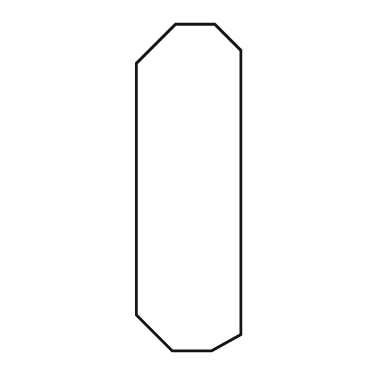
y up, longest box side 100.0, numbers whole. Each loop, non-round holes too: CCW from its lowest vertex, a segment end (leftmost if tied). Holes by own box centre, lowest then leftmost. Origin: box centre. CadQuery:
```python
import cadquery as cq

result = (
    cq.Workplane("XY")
    .moveTo(-5.0, -50.0)
    .lineTo(7.0, -50.0)
    .lineTo(16.0, -45.0)
    .lineTo(16.0, 42.0)
    .lineTo(8.0, 50.0)
    .lineTo(-4.0, 50.0)
    .lineTo(-16.0, 38.0)
    .lineTo(-16.0, -39.0)
    .close()
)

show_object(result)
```